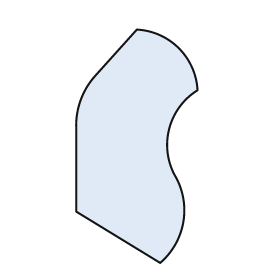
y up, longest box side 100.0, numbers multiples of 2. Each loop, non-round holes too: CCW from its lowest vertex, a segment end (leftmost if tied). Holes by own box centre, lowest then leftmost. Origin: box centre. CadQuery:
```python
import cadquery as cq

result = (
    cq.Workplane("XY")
    .moveTo(10.0, -50.0)
    .threePointArc((20.0, -32.0), (16.0, -12.0))
    .threePointArc((14.0, 8.0), (26.0, 24.0))
    .threePointArc((18.0, 42.0), (0.0, 50.0))
    .lineTo(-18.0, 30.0)
    .threePointArc((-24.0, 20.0), (-26.0, 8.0))
    .lineTo(-26.0, -28.0)
    .close()
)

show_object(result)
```